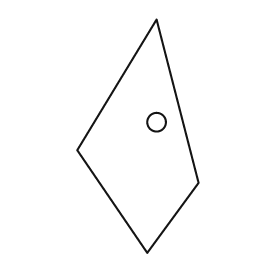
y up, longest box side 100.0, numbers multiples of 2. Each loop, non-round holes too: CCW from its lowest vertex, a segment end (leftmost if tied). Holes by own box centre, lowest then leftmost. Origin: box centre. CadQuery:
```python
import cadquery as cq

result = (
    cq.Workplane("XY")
    .moveTo(4.0, -50.0)
    .lineTo(26.0, -20.0)
    .lineTo(8.0, 50.0)
    .lineTo(-26.0, -6.0)
    .close()
    .moveTo(8.0, 6.0)
    .circle(4.0)
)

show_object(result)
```